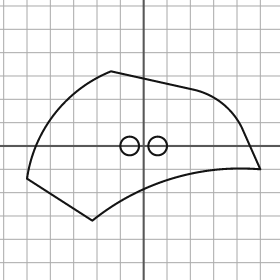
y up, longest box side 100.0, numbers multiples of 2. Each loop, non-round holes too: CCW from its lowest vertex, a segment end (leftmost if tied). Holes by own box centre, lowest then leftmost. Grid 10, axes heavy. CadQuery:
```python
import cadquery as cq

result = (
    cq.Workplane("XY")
    .moveTo(-22.0, -32.0)
    .threePointArc((12.0, -14.0), (50.0, -10.0))
    .lineTo(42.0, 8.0)
    .threePointArc((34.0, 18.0), (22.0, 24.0))
    .lineTo(-14.0, 32.0)
    .threePointArc((-38.0, 14.0), (-50.0, -14.0))
    .close()
    .moveTo(-6.0, 0.0)
    .circle(4.0)
    .moveTo(6.0, 0.0)
    .circle(4.0)
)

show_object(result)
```